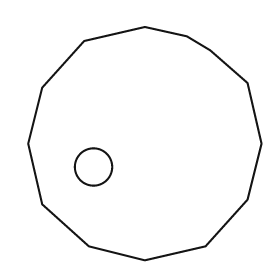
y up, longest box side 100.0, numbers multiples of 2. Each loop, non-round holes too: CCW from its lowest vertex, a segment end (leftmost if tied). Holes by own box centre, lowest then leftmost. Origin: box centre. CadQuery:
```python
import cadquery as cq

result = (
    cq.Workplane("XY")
    .moveTo(0.0, -50.0)
    .lineTo(26.0, -44.0)
    .lineTo(44.0, -24.0)
    .lineTo(50.0, 0.0)
    .lineTo(44.0, 26.0)
    .lineTo(28.0, 40.0)
    .lineTo(18.0, 46.0)
    .lineTo(0.0, 50.0)
    .lineTo(-26.0, 44.0)
    .lineTo(-44.0, 24.0)
    .lineTo(-50.0, 0.0)
    .lineTo(-44.0, -26.0)
    .lineTo(-24.0, -44.0)
    .close()
    .moveTo(-22.0, -10.0)
    .circle(8.0)
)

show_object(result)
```